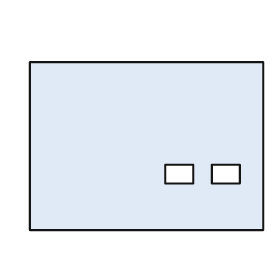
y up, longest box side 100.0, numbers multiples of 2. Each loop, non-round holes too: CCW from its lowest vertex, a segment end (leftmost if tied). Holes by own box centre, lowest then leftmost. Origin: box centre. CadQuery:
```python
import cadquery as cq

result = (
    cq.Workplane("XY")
    .moveTo(-50.0, -36.0)
    .lineTo(50.0, -36.0)
    .lineTo(50.0, 36.0)
    .lineTo(-50.0, 36.0)
    .close()
    .moveTo(8.0, -16.0)
    .lineTo(20.0, -16.0)
    .lineTo(20.0, -8.0)
    .lineTo(8.0, -8.0)
    .close()
    .moveTo(28.0, -16.0)
    .lineTo(40.0, -16.0)
    .lineTo(40.0, -8.0)
    .lineTo(28.0, -8.0)
    .close()
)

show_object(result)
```